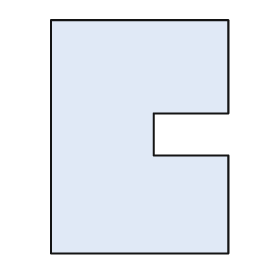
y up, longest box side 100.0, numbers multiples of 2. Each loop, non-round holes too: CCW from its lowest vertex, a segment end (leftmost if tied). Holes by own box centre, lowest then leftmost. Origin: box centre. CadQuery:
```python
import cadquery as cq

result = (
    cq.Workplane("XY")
    .moveTo(-38.0, -50.0)
    .lineTo(38.0, -50.0)
    .lineTo(38.0, -8.0)
    .lineTo(6.0, -8.0)
    .lineTo(6.0, 10.0)
    .lineTo(38.0, 10.0)
    .lineTo(38.0, 50.0)
    .lineTo(-38.0, 50.0)
    .close()
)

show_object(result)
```